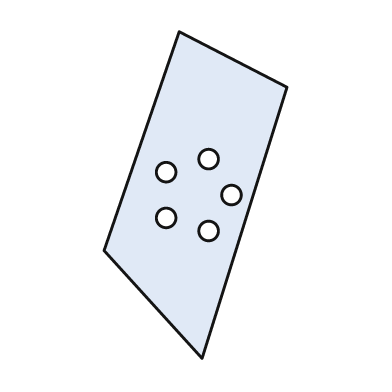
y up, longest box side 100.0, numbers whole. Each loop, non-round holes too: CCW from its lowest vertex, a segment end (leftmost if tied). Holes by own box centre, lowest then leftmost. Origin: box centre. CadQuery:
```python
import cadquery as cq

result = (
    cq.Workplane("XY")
    .moveTo(2.0, -50.0)
    .lineTo(28.0, 33.0)
    .lineTo(-5.0, 50.0)
    .lineTo(-28.0, -17.0)
    .close()
    .moveTo(4.0, -11.0)
    .circle(3.0)
    .moveTo(-9.0, -7.0)
    .circle(3.0)
    .moveTo(11.0, 0.0)
    .circle(3.0)
    .moveTo(-9.0, 7.0)
    .circle(3.0)
    .moveTo(4.0, 11.0)
    .circle(3.0)
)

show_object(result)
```